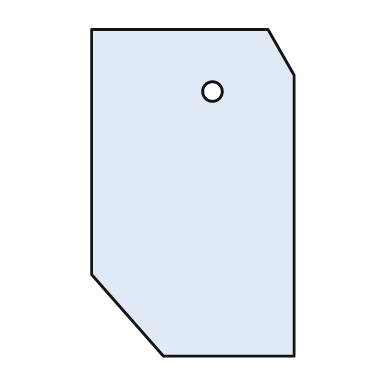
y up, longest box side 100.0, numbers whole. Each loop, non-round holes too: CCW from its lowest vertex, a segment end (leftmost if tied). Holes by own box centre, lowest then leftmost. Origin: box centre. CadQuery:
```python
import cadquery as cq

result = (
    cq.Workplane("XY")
    .moveTo(-9.0, -50.0)
    .lineTo(31.0, -50.0)
    .lineTo(31.0, 36.0)
    .lineTo(23.0, 50.0)
    .lineTo(-31.0, 50.0)
    .lineTo(-31.0, -25.0)
    .close()
    .moveTo(6.0, 31.0)
    .circle(3.0)
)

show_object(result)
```